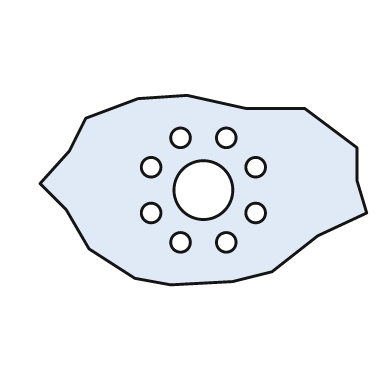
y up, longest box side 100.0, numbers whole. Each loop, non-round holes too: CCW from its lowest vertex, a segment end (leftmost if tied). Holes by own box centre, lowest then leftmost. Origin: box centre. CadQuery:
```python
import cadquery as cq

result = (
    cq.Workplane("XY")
    .moveTo(-10.0, -29.0)
    .lineTo(9.0, -28.0)
    .lineTo(21.0, -25.0)
    .lineTo(35.0, -14.0)
    .lineTo(50.0, -7.0)
    .lineTo(47.0, 3.0)
    .lineTo(47.0, 13.0)
    .lineTo(31.0, 25.0)
    .lineTo(13.0, 25.0)
    .lineTo(-5.0, 29.0)
    .lineTo(-20.0, 28.0)
    .lineTo(-36.0, 22.0)
    .lineTo(-41.0, 12.0)
    .lineTo(-50.0, 2.0)
    .lineTo(-42.0, -6.0)
    .lineTo(-35.0, -18.0)
    .lineTo(-21.0, -27.0)
    .close()
    .moveTo(-7.0, -16.0)
    .circle(3.0)
    .moveTo(7.0, -16.0)
    .circle(3.0)
    .moveTo(-16.0, -7.0)
    .circle(3.0)
    .moveTo(16.0, -7.0)
    .circle(3.0)
    .moveTo(0.0, 0.0)
    .circle(9.0)
    .moveTo(-16.0, 7.0)
    .circle(3.0)
    .moveTo(16.0, 7.0)
    .circle(3.0)
    .moveTo(-7.0, 16.0)
    .circle(3.0)
    .moveTo(7.0, 16.0)
    .circle(3.0)
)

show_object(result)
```